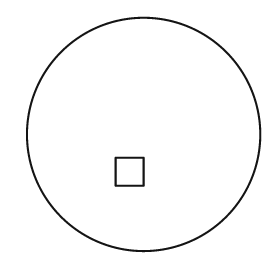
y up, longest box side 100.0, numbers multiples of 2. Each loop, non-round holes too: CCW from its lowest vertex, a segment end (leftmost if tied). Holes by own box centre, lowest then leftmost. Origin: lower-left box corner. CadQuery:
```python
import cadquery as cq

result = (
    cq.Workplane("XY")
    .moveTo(50.0, 50.0)
    .circle(50.0)
    .moveTo(38.0, 28.0)
    .lineTo(50.0, 28.0)
    .lineTo(50.0, 40.0)
    .lineTo(38.0, 40.0)
    .close()
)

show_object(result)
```